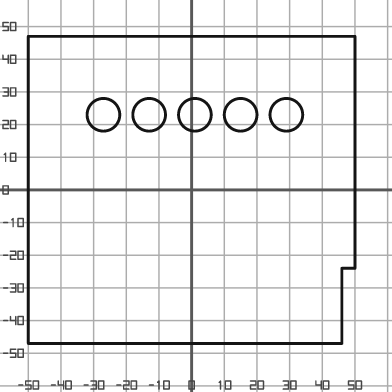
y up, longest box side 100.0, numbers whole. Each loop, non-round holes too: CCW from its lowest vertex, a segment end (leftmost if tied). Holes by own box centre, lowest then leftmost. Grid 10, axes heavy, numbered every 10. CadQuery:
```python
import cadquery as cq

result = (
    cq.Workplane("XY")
    .moveTo(-50.0, -47.0)
    .lineTo(46.0, -47.0)
    .lineTo(46.0, -24.0)
    .lineTo(50.0, -24.0)
    .lineTo(50.0, 47.0)
    .lineTo(-50.0, 47.0)
    .close()
    .moveTo(-27.0, 23.0)
    .circle(5.0)
    .moveTo(-13.0, 23.0)
    .circle(5.0)
    .moveTo(1.0, 23.0)
    .circle(5.0)
    .moveTo(15.0, 23.0)
    .circle(5.0)
    .moveTo(29.0, 23.0)
    .circle(5.0)
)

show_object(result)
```